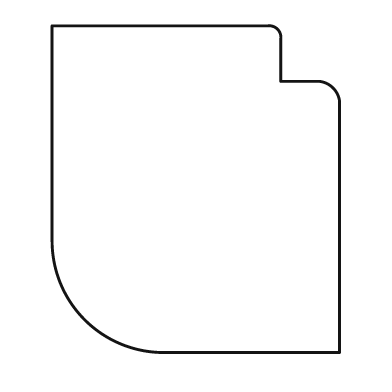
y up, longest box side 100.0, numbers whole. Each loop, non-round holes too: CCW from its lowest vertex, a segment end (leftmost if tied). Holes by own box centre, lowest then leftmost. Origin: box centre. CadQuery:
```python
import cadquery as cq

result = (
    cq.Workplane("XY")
    .moveTo(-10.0, -50.0)
    .lineTo(44.0, -50.0)
    .lineTo(44.0, 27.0)
    .threePointArc((42.0, 31.0), (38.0, 33.0))
    .lineTo(26.0, 33.0)
    .lineTo(26.0, 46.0)
    .threePointArc((25.0, 49.0), (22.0, 50.0))
    .lineTo(-44.0, 50.0)
    .lineTo(-44.0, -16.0)
    .threePointArc((-34.0, -40.0), (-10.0, -50.0))
    .close()
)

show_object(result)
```